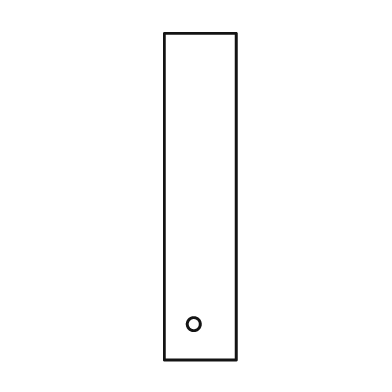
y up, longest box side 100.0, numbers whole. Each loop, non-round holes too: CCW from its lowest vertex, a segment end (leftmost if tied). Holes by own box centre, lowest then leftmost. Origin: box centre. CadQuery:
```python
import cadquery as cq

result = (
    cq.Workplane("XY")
    .moveTo(-11.0, -50.0)
    .lineTo(11.0, -50.0)
    .lineTo(11.0, 50.0)
    .lineTo(-11.0, 50.0)
    .close()
    .moveTo(-2.0, -39.0)
    .circle(2.0)
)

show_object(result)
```